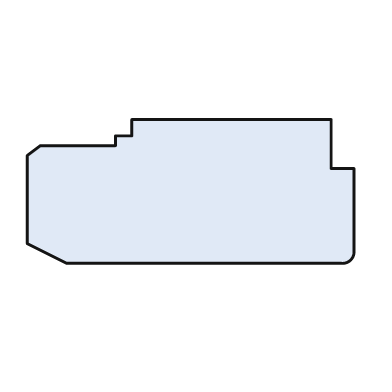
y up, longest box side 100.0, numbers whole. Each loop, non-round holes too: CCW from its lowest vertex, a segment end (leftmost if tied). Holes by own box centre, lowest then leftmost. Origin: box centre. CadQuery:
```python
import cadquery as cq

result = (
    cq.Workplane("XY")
    .moveTo(-38.0, -22.0)
    .lineTo(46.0, -22.0)
    .threePointArc((49.0, -21.0), (50.0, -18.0))
    .lineTo(50.0, 7.0)
    .lineTo(43.0, 7.0)
    .lineTo(43.0, 22.0)
    .lineTo(-18.0, 22.0)
    .lineTo(-18.0, 17.0)
    .lineTo(-23.0, 17.0)
    .lineTo(-23.0, 14.0)
    .lineTo(-46.0, 14.0)
    .lineTo(-50.0, 11.0)
    .lineTo(-50.0, -16.0)
    .close()
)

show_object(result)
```